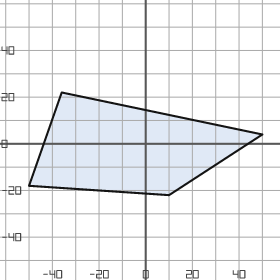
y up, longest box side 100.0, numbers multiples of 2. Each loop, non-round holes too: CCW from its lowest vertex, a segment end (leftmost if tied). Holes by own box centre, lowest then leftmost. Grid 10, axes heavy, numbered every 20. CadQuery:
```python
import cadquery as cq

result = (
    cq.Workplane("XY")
    .moveTo(10.0, -22.0)
    .lineTo(50.0, 4.0)
    .lineTo(-36.0, 22.0)
    .lineTo(-50.0, -18.0)
    .close()
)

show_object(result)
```